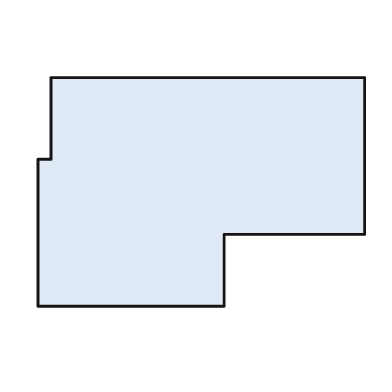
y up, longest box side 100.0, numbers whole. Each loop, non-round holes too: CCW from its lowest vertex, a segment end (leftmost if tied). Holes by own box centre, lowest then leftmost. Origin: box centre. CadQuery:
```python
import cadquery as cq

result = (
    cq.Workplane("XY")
    .moveTo(-50.0, -35.0)
    .lineTo(7.0, -35.0)
    .lineTo(7.0, -13.0)
    .lineTo(50.0, -13.0)
    .lineTo(50.0, 35.0)
    .lineTo(-46.0, 35.0)
    .lineTo(-46.0, 10.0)
    .lineTo(-50.0, 10.0)
    .close()
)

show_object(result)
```